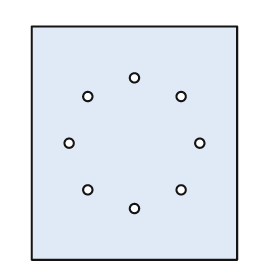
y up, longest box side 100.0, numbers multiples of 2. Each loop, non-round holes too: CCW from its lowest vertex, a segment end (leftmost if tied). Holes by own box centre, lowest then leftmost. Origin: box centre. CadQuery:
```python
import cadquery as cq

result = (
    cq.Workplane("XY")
    .moveTo(-44.0, -50.0)
    .lineTo(44.0, -50.0)
    .lineTo(44.0, 50.0)
    .lineTo(-44.0, 50.0)
    .close()
    .moveTo(0.0, -28.0)
    .circle(2.0)
    .moveTo(-20.0, -20.0)
    .circle(2.0)
    .moveTo(20.0, -20.0)
    .circle(2.0)
    .moveTo(-28.0, 0.0)
    .circle(2.0)
    .moveTo(28.0, 0.0)
    .circle(2.0)
    .moveTo(-20.0, 20.0)
    .circle(2.0)
    .moveTo(20.0, 20.0)
    .circle(2.0)
    .moveTo(0.0, 28.0)
    .circle(2.0)
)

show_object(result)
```